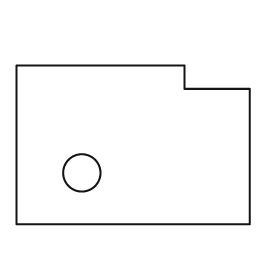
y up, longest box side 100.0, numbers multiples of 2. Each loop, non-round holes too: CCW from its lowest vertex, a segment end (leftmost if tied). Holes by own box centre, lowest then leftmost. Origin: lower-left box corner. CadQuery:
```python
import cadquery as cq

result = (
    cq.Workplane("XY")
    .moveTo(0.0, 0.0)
    .lineTo(100.0, 0.0)
    .lineTo(100.0, 58.0)
    .lineTo(72.0, 58.0)
    .lineTo(72.0, 68.0)
    .lineTo(0.0, 68.0)
    .close()
    .moveTo(28.0, 22.0)
    .circle(8.0)
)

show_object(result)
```